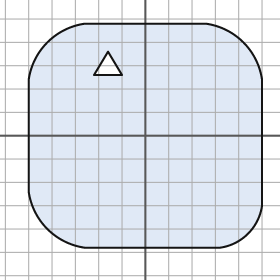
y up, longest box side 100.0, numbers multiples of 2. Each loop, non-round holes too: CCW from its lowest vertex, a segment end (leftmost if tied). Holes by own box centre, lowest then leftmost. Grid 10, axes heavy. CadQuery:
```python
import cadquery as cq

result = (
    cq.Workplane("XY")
    .moveTo(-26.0, -48.0)
    .lineTo(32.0, -48.0)
    .threePointArc((44.0, -42.0), (50.0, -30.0))
    .lineTo(50.0, 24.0)
    .threePointArc((42.0, 40.0), (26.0, 48.0))
    .lineTo(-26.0, 48.0)
    .threePointArc((-42.0, 40.0), (-50.0, 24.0))
    .lineTo(-50.0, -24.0)
    .threePointArc((-42.0, -40.0), (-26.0, -48.0))
    .close()
    .moveTo(-22.0, 26.0)
    .lineTo(-10.0, 26.0)
    .lineTo(-16.0, 36.0)
    .close()
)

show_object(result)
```